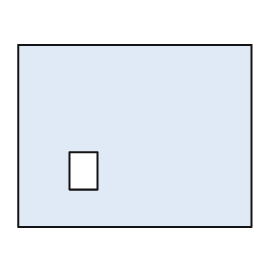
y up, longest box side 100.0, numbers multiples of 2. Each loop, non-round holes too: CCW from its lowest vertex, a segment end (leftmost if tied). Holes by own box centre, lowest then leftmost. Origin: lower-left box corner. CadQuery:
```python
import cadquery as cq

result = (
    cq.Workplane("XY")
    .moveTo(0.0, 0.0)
    .lineTo(100.0, 0.0)
    .lineTo(100.0, 78.0)
    .lineTo(0.0, 78.0)
    .close()
    .moveTo(22.0, 16.0)
    .lineTo(34.0, 16.0)
    .lineTo(34.0, 32.0)
    .lineTo(22.0, 32.0)
    .close()
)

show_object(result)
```